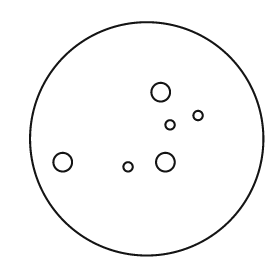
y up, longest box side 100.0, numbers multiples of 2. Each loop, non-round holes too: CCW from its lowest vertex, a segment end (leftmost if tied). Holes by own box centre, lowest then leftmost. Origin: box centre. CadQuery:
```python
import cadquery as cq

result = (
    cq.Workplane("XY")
    .moveTo(0.0, 0.0)
    .circle(50.0)
    .moveTo(-8.0, -12.0)
    .circle(2.0)
    .moveTo(-36.0, -10.0)
    .circle(4.0)
    .moveTo(8.0, -10.0)
    .circle(4.0)
    .moveTo(10.0, 6.0)
    .circle(2.0)
    .moveTo(22.0, 10.0)
    .circle(2.0)
    .moveTo(6.0, 20.0)
    .circle(4.0)
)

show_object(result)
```